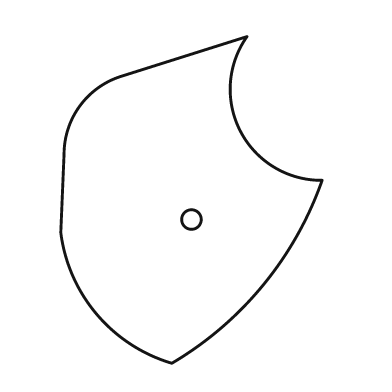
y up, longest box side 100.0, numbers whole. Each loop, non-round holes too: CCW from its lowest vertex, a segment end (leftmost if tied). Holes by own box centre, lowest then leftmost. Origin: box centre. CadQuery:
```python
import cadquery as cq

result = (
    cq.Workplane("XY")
    .moveTo(-6.0, -50.0)
    .threePointArc((22.0, -26.0), (40.0, 6.0))
    .threePointArc((15.0, 21.0), (17.0, 50.0))
    .lineTo(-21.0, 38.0)
    .threePointArc((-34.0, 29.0), (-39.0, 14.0))
    .lineTo(-40.0, -10.0)
    .threePointArc((-29.0, -35.0), (-6.0, -50.0))
    .close()
    .moveTo(0.0, -6.0)
    .circle(3.0)
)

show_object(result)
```